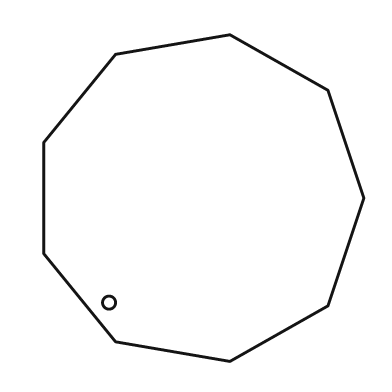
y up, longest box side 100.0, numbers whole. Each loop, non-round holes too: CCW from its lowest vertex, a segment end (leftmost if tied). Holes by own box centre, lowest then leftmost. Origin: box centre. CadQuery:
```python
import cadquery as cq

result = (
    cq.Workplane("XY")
    .moveTo(8.0, -50.0)
    .lineTo(38.0, -33.0)
    .lineTo(49.0, 0.0)
    .lineTo(38.0, 33.0)
    .lineTo(8.0, 50.0)
    .lineTo(-27.0, 44.0)
    .lineTo(-49.0, 17.0)
    .lineTo(-49.0, -17.0)
    .lineTo(-27.0, -44.0)
    .close()
    .moveTo(-29.0, -32.0)
    .circle(2.0)
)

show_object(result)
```